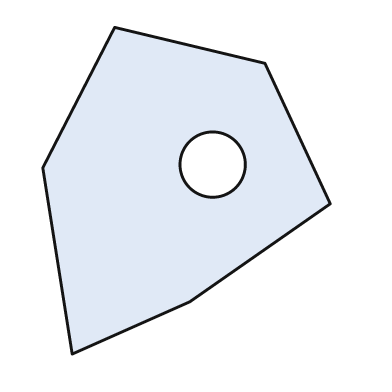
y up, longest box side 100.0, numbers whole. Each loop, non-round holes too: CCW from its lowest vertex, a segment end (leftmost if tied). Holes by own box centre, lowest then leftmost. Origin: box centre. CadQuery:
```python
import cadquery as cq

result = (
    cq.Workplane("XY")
    .moveTo(-35.0, -50.0)
    .lineTo(1.0, -34.0)
    .lineTo(44.0, -4.0)
    .lineTo(24.0, 39.0)
    .lineTo(-22.0, 50.0)
    .lineTo(-44.0, 7.0)
    .close()
    .moveTo(8.0, 8.0)
    .circle(10.0)
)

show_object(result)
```